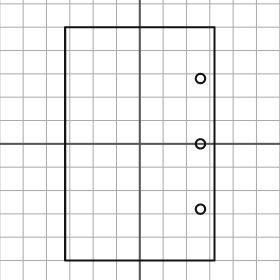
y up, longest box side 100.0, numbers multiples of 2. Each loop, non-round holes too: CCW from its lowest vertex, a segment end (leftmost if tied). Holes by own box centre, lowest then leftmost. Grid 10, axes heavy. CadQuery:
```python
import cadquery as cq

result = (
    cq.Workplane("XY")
    .moveTo(-32.0, -50.0)
    .lineTo(32.0, -50.0)
    .lineTo(32.0, 50.0)
    .lineTo(-32.0, 50.0)
    .close()
    .moveTo(26.0, -28.0)
    .circle(2.0)
    .moveTo(26.0, 0.0)
    .circle(2.0)
    .moveTo(26.0, 28.0)
    .circle(2.0)
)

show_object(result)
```